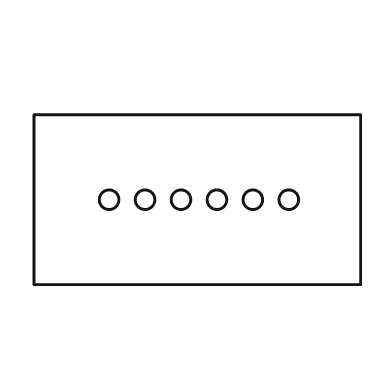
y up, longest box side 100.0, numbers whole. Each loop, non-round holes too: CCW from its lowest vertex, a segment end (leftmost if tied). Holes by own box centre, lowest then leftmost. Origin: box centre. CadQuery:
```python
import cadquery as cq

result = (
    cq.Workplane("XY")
    .moveTo(-50.0, -26.0)
    .lineTo(50.0, -26.0)
    .lineTo(50.0, 26.0)
    .lineTo(-50.0, 26.0)
    .close()
    .moveTo(-27.0, 0.0)
    .circle(3.0)
    .moveTo(-16.0, 0.0)
    .circle(3.0)
    .moveTo(-5.0, 0.0)
    .circle(3.0)
    .moveTo(6.0, 0.0)
    .circle(3.0)
    .moveTo(17.0, 0.0)
    .circle(3.0)
    .moveTo(28.0, 0.0)
    .circle(3.0)
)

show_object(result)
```